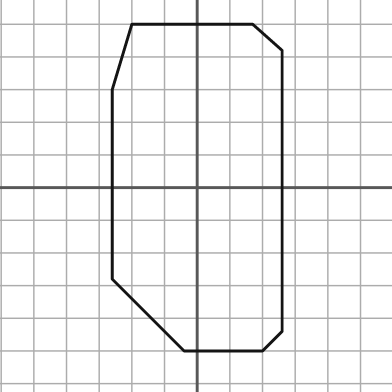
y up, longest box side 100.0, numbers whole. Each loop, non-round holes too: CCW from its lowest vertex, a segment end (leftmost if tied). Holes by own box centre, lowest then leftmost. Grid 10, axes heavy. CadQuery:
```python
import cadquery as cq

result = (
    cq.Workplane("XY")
    .moveTo(-4.0, -50.0)
    .lineTo(20.0, -50.0)
    .lineTo(26.0, -44.0)
    .lineTo(26.0, 42.0)
    .lineTo(17.0, 50.0)
    .lineTo(-20.0, 50.0)
    .lineTo(-26.0, 30.0)
    .lineTo(-26.0, -28.0)
    .close()
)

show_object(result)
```